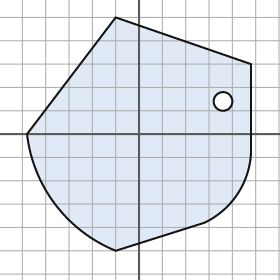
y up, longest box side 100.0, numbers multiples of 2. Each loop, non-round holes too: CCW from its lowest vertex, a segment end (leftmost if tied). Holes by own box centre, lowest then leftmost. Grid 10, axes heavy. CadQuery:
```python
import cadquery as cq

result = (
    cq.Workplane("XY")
    .moveTo(-10.0, -50.0)
    .lineTo(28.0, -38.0)
    .threePointArc((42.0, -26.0), (48.0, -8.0))
    .lineTo(48.0, 30.0)
    .lineTo(-10.0, 50.0)
    .lineTo(-48.0, 0.0)
    .threePointArc((-36.0, -30.0), (-10.0, -50.0))
    .close()
    .moveTo(36.0, 14.0)
    .circle(4.0)
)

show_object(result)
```